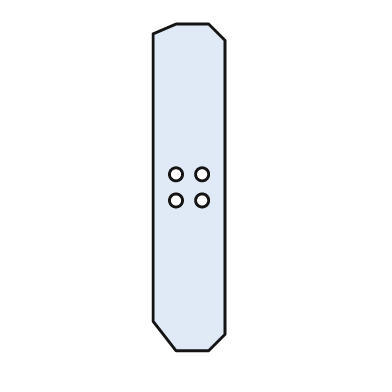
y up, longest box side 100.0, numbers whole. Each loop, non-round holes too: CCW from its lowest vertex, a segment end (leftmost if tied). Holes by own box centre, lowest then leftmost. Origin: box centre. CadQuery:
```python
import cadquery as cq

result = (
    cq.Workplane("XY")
    .moveTo(-4.0, -50.0)
    .lineTo(6.0, -50.0)
    .lineTo(11.0, -45.0)
    .lineTo(11.0, 45.0)
    .lineTo(6.0, 50.0)
    .lineTo(-4.0, 50.0)
    .lineTo(-11.0, 47.0)
    .lineTo(-11.0, -41.0)
    .close()
    .moveTo(-4.0, -4.0)
    .circle(2.0)
    .moveTo(4.0, -4.0)
    .circle(2.0)
    .moveTo(-4.0, 4.0)
    .circle(2.0)
    .moveTo(4.0, 4.0)
    .circle(2.0)
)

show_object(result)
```